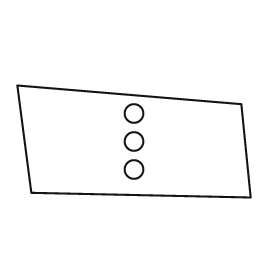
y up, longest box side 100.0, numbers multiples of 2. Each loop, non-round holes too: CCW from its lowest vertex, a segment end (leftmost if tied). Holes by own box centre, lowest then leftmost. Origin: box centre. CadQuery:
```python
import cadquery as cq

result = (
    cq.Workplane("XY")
    .moveTo(50.0, -24.0)
    .lineTo(46.0, 16.0)
    .lineTo(-50.0, 24.0)
    .lineTo(-44.0, -22.0)
    .close()
    .moveTo(0.0, -12.0)
    .circle(4.0)
    .moveTo(0.0, 0.0)
    .circle(4.0)
    .moveTo(0.0, 12.0)
    .circle(4.0)
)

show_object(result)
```